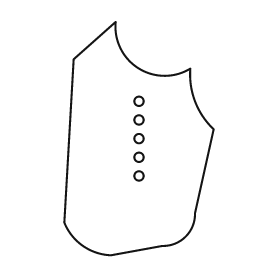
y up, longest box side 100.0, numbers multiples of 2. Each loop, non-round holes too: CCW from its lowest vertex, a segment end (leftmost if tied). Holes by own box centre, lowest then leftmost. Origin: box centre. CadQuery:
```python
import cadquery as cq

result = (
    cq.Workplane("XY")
    .moveTo(-12.0, -50.0)
    .lineTo(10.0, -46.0)
    .threePointArc((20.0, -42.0), (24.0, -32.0))
    .lineTo(32.0, 4.0)
    .threePointArc((24.0, 16.0), (22.0, 30.0))
    .threePointArc((0.0, 30.0), (-10.0, 50.0))
    .lineTo(-28.0, 34.0)
    .lineTo(-32.0, -36.0)
    .threePointArc((-24.0, -46.0), (-12.0, -50.0))
    .close()
    .moveTo(0.0, -16.0)
    .circle(2.0)
    .moveTo(0.0, -8.0)
    .circle(2.0)
    .moveTo(0.0, 0.0)
    .circle(2.0)
    .moveTo(0.0, 8.0)
    .circle(2.0)
    .moveTo(0.0, 16.0)
    .circle(2.0)
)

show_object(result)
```